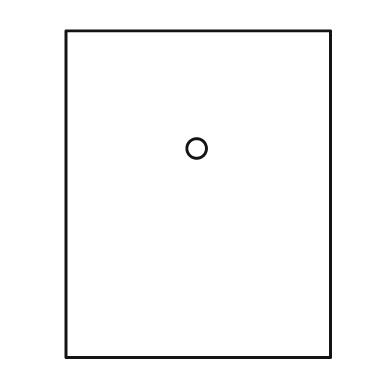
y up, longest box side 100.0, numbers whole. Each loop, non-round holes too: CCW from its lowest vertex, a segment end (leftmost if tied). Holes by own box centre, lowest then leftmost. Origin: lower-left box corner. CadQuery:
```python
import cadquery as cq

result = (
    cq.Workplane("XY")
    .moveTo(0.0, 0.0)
    .lineTo(81.0, 0.0)
    .lineTo(81.0, 100.0)
    .lineTo(0.0, 100.0)
    .close()
    .moveTo(40.0, 64.0)
    .circle(3.0)
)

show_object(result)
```